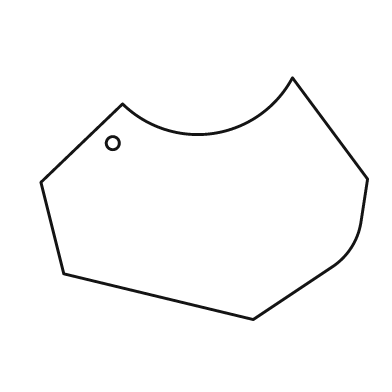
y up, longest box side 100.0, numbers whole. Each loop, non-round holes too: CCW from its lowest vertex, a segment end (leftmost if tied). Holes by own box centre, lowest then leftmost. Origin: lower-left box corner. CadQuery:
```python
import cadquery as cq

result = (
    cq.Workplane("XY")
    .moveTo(65.0, 0.0)
    .lineTo(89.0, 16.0)
    .threePointArc((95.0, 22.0), (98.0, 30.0))
    .lineTo(100.0, 43.0)
    .lineTo(77.0, 74.0)
    .threePointArc((53.0, 57.0), (25.0, 66.0))
    .lineTo(0.0, 42.0)
    .lineTo(7.0, 14.0)
    .close()
    .moveTo(22.0, 54.0)
    .circle(2.0)
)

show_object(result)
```